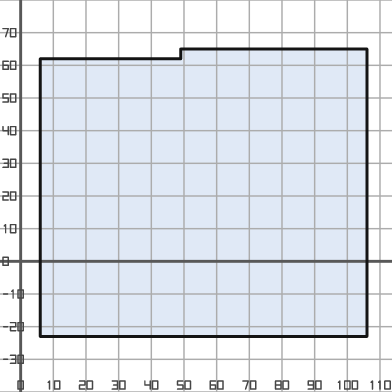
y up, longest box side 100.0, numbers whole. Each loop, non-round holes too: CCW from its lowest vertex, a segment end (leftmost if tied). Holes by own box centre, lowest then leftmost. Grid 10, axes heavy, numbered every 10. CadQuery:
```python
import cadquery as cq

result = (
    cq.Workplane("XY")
    .moveTo(6.0, -23.0)
    .lineTo(106.0, -23.0)
    .lineTo(106.0, 65.0)
    .lineTo(49.0, 65.0)
    .lineTo(49.0, 62.0)
    .lineTo(6.0, 62.0)
    .close()
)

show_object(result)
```